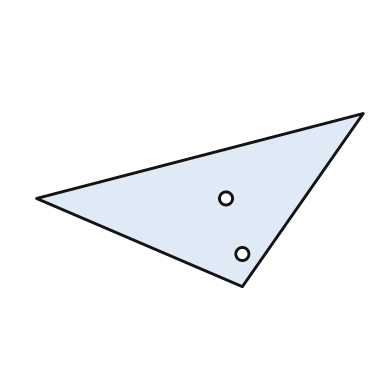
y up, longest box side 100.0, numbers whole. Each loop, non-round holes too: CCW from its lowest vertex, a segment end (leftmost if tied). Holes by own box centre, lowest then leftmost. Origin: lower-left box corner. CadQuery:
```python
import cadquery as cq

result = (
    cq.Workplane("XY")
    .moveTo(63.0, 0.0)
    .lineTo(100.0, 53.0)
    .lineTo(0.0, 27.0)
    .close()
    .moveTo(63.0, 10.0)
    .circle(2.0)
    .moveTo(58.0, 27.0)
    .circle(2.0)
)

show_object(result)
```